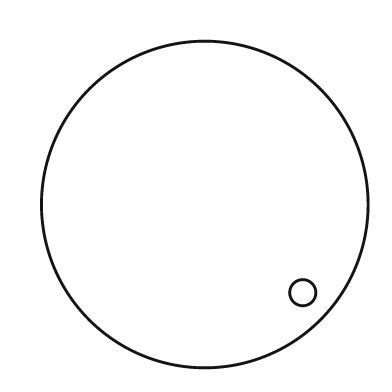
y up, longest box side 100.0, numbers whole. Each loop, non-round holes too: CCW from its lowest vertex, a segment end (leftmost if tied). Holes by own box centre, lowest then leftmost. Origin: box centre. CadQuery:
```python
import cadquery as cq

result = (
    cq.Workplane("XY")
    .moveTo(0.0, 0.0)
    .circle(50.0)
    .moveTo(30.0, -27.0)
    .circle(4.0)
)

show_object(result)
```